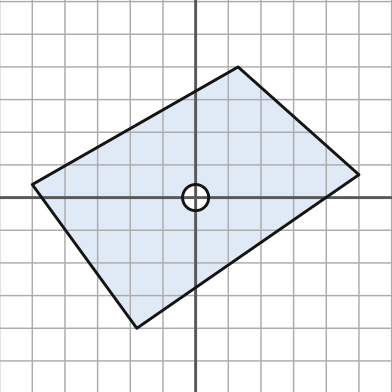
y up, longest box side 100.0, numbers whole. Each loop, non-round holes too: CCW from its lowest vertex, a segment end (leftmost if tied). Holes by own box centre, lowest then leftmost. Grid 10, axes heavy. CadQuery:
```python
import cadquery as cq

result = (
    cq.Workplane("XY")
    .moveTo(-18.0, -40.0)
    .lineTo(50.0, 7.0)
    .lineTo(13.0, 40.0)
    .lineTo(-50.0, 4.0)
    .close()
    .moveTo(0.0, 0.0)
    .circle(4.0)
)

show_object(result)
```